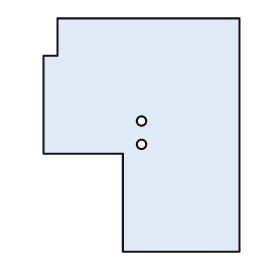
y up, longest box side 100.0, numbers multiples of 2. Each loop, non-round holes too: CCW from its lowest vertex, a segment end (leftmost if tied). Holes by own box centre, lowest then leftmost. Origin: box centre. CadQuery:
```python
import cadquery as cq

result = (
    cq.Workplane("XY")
    .moveTo(-8.0, -50.0)
    .lineTo(42.0, -50.0)
    .lineTo(42.0, 50.0)
    .lineTo(-36.0, 50.0)
    .lineTo(-36.0, 34.0)
    .lineTo(-42.0, 34.0)
    .lineTo(-42.0, -8.0)
    .lineTo(-8.0, -8.0)
    .close()
    .moveTo(0.0, -4.0)
    .circle(2.0)
    .moveTo(0.0, 6.0)
    .circle(2.0)
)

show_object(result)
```